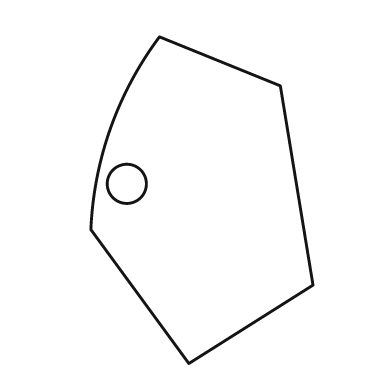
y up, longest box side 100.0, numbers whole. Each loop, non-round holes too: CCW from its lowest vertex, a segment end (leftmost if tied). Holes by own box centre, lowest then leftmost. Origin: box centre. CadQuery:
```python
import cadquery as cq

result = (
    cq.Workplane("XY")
    .moveTo(-4.0, -50.0)
    .lineTo(34.0, -26.0)
    .lineTo(24.0, 35.0)
    .lineTo(-13.0, 50.0)
    .threePointArc((-28.0, 22.0), (-34.0, -9.0))
    .close()
    .moveTo(-23.0, 5.0)
    .circle(6.0)
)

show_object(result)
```